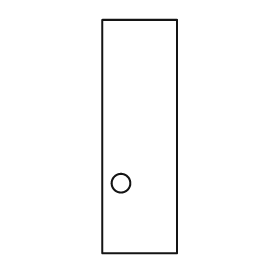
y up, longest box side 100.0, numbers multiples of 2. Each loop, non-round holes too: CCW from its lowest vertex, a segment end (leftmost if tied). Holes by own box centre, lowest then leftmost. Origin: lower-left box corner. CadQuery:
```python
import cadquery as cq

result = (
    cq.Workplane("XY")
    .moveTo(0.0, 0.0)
    .lineTo(32.0, 0.0)
    .lineTo(32.0, 100.0)
    .lineTo(0.0, 100.0)
    .close()
    .moveTo(8.0, 30.0)
    .circle(4.0)
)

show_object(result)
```